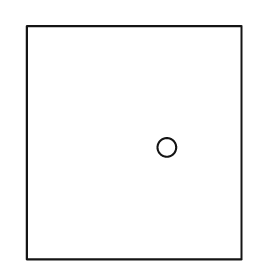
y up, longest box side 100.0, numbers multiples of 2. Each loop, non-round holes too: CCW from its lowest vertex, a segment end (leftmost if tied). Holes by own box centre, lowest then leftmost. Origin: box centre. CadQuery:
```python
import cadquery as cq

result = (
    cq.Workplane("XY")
    .moveTo(-46.0, -50.0)
    .lineTo(46.0, -50.0)
    .lineTo(46.0, 50.0)
    .lineTo(-46.0, 50.0)
    .close()
    .moveTo(14.0, -2.0)
    .circle(4.0)
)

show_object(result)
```